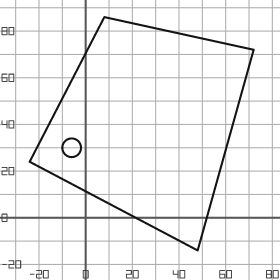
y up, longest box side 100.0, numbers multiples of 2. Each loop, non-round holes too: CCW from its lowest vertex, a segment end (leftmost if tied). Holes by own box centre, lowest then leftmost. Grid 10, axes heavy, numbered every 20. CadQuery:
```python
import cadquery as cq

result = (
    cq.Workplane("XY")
    .moveTo(48.0, -14.0)
    .lineTo(72.0, 72.0)
    .lineTo(8.0, 86.0)
    .lineTo(-24.0, 24.0)
    .close()
    .moveTo(-6.0, 30.0)
    .circle(4.0)
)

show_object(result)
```